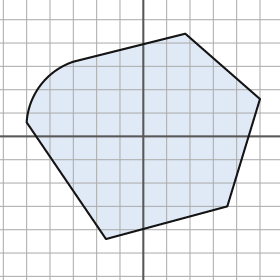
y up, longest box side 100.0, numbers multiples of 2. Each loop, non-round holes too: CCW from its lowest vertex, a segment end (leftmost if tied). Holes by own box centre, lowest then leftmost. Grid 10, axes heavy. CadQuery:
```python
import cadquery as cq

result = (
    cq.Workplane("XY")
    .moveTo(-16.0, -44.0)
    .lineTo(36.0, -30.0)
    .lineTo(50.0, 16.0)
    .lineTo(18.0, 44.0)
    .lineTo(-30.0, 32.0)
    .threePointArc((-44.0, 22.0), (-50.0, 6.0))
    .close()
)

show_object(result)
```